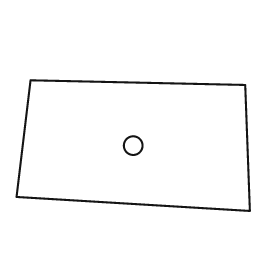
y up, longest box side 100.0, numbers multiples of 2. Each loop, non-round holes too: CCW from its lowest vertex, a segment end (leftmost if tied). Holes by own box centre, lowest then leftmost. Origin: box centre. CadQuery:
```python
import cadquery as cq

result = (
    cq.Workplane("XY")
    .moveTo(50.0, -28.0)
    .lineTo(48.0, 26.0)
    .lineTo(-44.0, 28.0)
    .lineTo(-50.0, -22.0)
    .close()
    .moveTo(0.0, 0.0)
    .circle(4.0)
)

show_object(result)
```